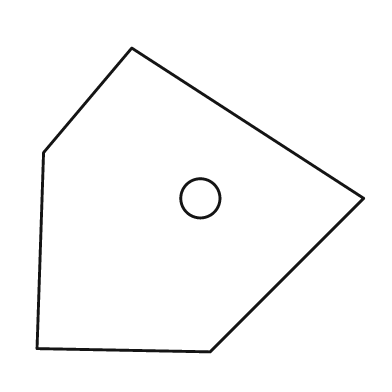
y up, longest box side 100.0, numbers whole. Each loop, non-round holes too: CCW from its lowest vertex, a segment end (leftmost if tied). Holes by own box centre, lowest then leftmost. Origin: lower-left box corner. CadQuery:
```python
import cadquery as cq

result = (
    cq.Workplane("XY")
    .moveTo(53.0, 0.0)
    .lineTo(100.0, 47.0)
    .lineTo(29.0, 93.0)
    .lineTo(2.0, 61.0)
    .lineTo(0.0, 1.0)
    .close()
    .moveTo(50.0, 47.0)
    .circle(6.0)
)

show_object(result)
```